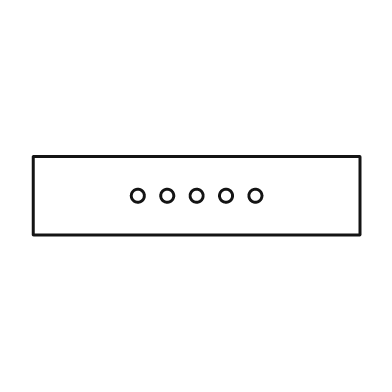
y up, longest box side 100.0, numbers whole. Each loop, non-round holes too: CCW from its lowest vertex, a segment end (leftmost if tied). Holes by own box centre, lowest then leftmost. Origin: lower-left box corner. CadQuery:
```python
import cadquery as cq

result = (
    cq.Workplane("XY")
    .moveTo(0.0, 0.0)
    .lineTo(100.0, 0.0)
    .lineTo(100.0, 24.0)
    .lineTo(0.0, 24.0)
    .close()
    .moveTo(32.0, 12.0)
    .circle(2.0)
    .moveTo(41.0, 12.0)
    .circle(2.0)
    .moveTo(50.0, 12.0)
    .circle(2.0)
    .moveTo(59.0, 12.0)
    .circle(2.0)
    .moveTo(68.0, 12.0)
    .circle(2.0)
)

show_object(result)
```